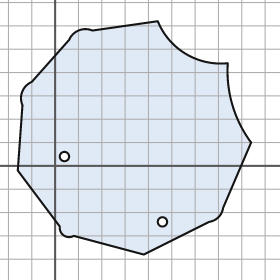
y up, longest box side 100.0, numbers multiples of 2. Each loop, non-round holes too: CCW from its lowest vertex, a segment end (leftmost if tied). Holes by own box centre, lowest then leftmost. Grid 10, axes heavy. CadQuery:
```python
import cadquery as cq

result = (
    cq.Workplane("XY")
    .moveTo(38.0, -38.0)
    .lineTo(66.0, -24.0)
    .threePointArc((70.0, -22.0), (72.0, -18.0))
    .lineTo(84.0, 10.0)
    .threePointArc((76.0, 26.0), (74.0, 44.0))
    .threePointArc((56.0, 48.0), (44.0, 62.0))
    .lineTo(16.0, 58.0)
    .threePointArc((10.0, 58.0), (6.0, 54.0))
    .lineTo(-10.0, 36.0)
    .threePointArc((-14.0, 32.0), (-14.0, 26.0))
    .lineTo(-16.0, -2.0)
    .lineTo(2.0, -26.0)
    .threePointArc((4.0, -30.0), (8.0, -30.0))
    .close()
    .moveTo(46.0, -24.0)
    .circle(2.0)
    .moveTo(4.0, 4.0)
    .circle(2.0)
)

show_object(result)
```